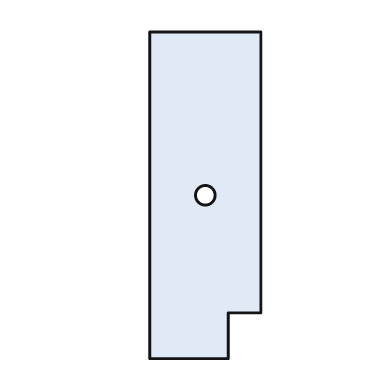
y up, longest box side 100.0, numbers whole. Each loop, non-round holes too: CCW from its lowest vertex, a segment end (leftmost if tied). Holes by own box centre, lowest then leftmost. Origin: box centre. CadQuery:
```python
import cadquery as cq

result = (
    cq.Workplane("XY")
    .moveTo(-17.0, -50.0)
    .lineTo(7.0, -50.0)
    .lineTo(7.0, -36.0)
    .lineTo(17.0, -36.0)
    .lineTo(17.0, 50.0)
    .lineTo(-17.0, 50.0)
    .close()
    .moveTo(0.0, 0.0)
    .circle(3.0)
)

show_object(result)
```